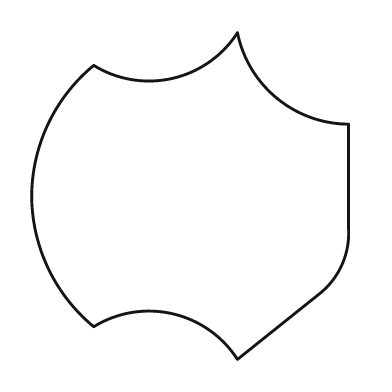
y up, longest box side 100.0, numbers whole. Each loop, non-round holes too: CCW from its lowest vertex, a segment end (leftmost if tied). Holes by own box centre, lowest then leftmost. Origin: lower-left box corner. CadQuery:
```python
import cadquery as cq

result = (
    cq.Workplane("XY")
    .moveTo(63.0, 0.0)
    .lineTo(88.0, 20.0)
    .threePointArc((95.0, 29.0), (97.0, 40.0))
    .lineTo(97.0, 72.0)
    .threePointArc((75.0, 80.0), (63.0, 100.0))
    .threePointArc((43.0, 86.0), (19.0, 90.0))
    .threePointArc((5.0, 72.0), (0.0, 50.0))
    .threePointArc((5.0, 28.0), (19.0, 10.0))
    .threePointArc((43.0, 14.0), (63.0, 0.0))
    .close()
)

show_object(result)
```